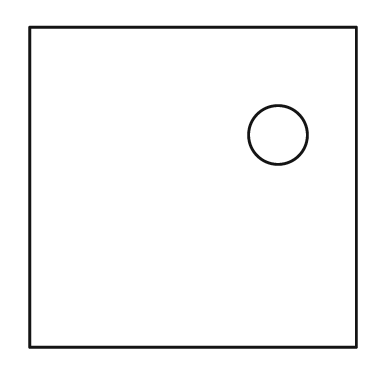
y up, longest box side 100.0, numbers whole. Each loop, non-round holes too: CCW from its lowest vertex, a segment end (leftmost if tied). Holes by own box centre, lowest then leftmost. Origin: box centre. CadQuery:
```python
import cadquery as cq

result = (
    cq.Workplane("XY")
    .moveTo(-50.0, -49.0)
    .lineTo(50.0, -49.0)
    .lineTo(50.0, 49.0)
    .lineTo(-50.0, 49.0)
    .close()
    .moveTo(26.0, 16.0)
    .circle(9.0)
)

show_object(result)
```